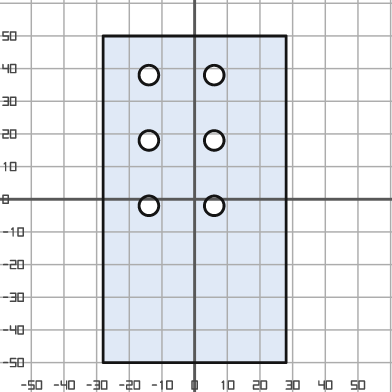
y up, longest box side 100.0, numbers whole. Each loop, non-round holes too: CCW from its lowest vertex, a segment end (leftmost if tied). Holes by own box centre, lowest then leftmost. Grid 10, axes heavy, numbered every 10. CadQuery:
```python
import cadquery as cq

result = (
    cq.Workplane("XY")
    .moveTo(-28.0, -50.0)
    .lineTo(28.0, -50.0)
    .lineTo(28.0, 50.0)
    .lineTo(-28.0, 50.0)
    .close()
    .moveTo(-14.0, -2.0)
    .circle(3.0)
    .moveTo(6.0, -2.0)
    .circle(3.0)
    .moveTo(-14.0, 18.0)
    .circle(3.0)
    .moveTo(6.0, 18.0)
    .circle(3.0)
    .moveTo(-14.0, 38.0)
    .circle(3.0)
    .moveTo(6.0, 38.0)
    .circle(3.0)
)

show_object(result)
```